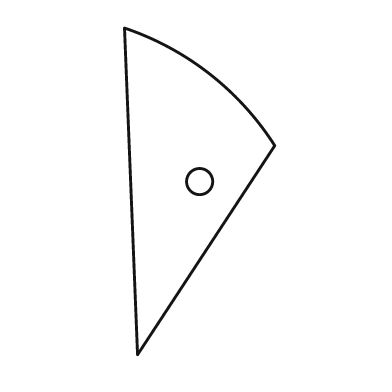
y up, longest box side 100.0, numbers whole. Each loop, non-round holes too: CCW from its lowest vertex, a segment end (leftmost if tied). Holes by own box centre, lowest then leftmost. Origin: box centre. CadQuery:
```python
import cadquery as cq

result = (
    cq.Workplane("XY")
    .moveTo(-19.0, -50.0)
    .lineTo(23.0, 14.0)
    .threePointArc((3.0, 36.0), (-23.0, 50.0))
    .close()
    .moveTo(0.0, 3.0)
    .circle(4.0)
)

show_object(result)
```